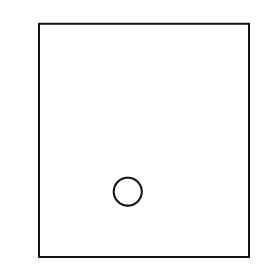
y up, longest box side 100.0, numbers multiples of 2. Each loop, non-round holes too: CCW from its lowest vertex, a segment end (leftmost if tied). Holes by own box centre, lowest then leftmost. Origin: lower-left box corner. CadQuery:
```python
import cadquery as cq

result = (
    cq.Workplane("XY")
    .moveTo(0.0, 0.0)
    .lineTo(90.0, 0.0)
    .lineTo(90.0, 100.0)
    .lineTo(0.0, 100.0)
    .close()
    .moveTo(38.0, 28.0)
    .circle(6.0)
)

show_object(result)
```